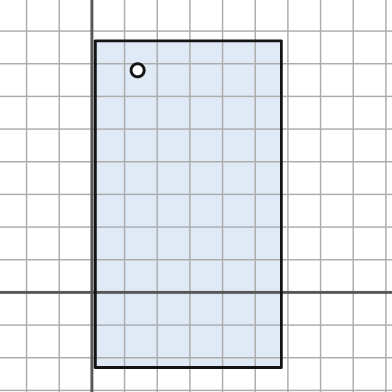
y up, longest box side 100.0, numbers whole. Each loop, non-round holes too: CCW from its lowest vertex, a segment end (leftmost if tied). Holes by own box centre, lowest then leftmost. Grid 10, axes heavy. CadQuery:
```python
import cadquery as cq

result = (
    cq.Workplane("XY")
    .moveTo(1.0, -23.0)
    .lineTo(58.0, -23.0)
    .lineTo(58.0, 77.0)
    .lineTo(1.0, 77.0)
    .close()
    .moveTo(14.0, 68.0)
    .circle(2.0)
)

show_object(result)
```